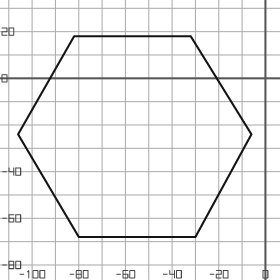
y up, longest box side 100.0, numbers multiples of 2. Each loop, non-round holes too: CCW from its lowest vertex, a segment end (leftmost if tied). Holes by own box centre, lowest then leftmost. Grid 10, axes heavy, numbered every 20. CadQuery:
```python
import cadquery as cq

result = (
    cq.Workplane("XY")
    .moveTo(-80.0, -68.0)
    .lineTo(-30.0, -68.0)
    .lineTo(-6.0, -24.0)
    .lineTo(-32.0, 18.0)
    .lineTo(-82.0, 18.0)
    .lineTo(-106.0, -24.0)
    .close()
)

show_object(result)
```